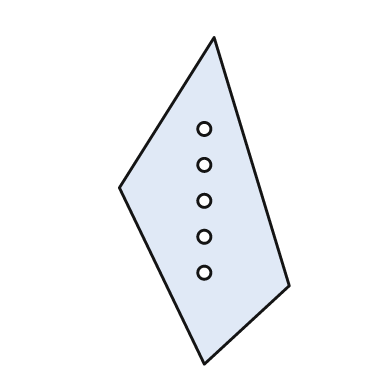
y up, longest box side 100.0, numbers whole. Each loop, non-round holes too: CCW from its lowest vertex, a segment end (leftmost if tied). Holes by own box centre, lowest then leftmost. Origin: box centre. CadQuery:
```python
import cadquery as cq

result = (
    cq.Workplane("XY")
    .moveTo(0.0, -50.0)
    .lineTo(26.0, -26.0)
    .lineTo(3.0, 50.0)
    .lineTo(-26.0, 4.0)
    .close()
    .moveTo(0.0, -22.0)
    .circle(2.0)
    .moveTo(0.0, -11.0)
    .circle(2.0)
    .moveTo(0.0, 0.0)
    .circle(2.0)
    .moveTo(0.0, 11.0)
    .circle(2.0)
    .moveTo(0.0, 22.0)
    .circle(2.0)
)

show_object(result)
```